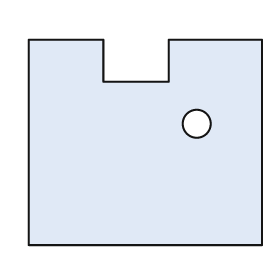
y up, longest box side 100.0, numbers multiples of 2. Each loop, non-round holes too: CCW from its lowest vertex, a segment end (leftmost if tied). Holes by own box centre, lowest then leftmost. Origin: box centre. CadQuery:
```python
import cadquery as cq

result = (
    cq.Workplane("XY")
    .moveTo(-50.0, -44.0)
    .lineTo(50.0, -44.0)
    .lineTo(50.0, 44.0)
    .lineTo(10.0, 44.0)
    .lineTo(10.0, 26.0)
    .lineTo(-18.0, 26.0)
    .lineTo(-18.0, 44.0)
    .lineTo(-50.0, 44.0)
    .close()
    .moveTo(22.0, 8.0)
    .circle(6.0)
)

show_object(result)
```